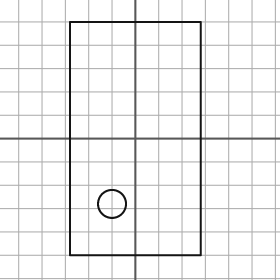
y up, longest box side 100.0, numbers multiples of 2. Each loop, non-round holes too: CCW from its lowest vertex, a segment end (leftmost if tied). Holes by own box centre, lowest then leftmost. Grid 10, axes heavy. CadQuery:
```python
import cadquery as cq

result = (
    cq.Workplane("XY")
    .moveTo(-28.0, -50.0)
    .lineTo(28.0, -50.0)
    .lineTo(28.0, 50.0)
    .lineTo(-28.0, 50.0)
    .close()
    .moveTo(-10.0, -28.0)
    .circle(6.0)
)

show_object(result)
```